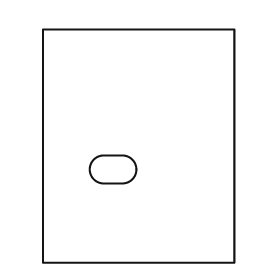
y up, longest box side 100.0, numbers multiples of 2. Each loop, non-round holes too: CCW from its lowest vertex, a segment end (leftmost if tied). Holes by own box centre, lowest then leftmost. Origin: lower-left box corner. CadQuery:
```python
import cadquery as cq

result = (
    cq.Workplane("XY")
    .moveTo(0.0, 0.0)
    .lineTo(82.0, 0.0)
    .lineTo(82.0, 100.0)
    .lineTo(0.0, 100.0)
    .close()
    .moveTo(26.0, 34.0)
    .lineTo(34.0, 34.0)
    .threePointArc((40.0, 40.0), (34.0, 46.0))
    .lineTo(26.0, 46.0)
    .threePointArc((20.0, 40.0), (26.0, 34.0))
    .close()
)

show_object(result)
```